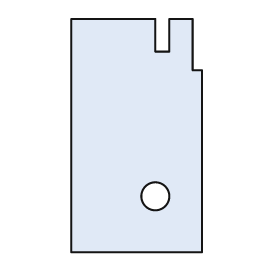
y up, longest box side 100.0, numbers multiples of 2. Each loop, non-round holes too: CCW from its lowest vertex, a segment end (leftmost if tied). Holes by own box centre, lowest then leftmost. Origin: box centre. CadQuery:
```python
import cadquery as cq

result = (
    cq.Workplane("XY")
    .moveTo(-28.0, -50.0)
    .lineTo(28.0, -50.0)
    .lineTo(28.0, 28.0)
    .lineTo(24.0, 28.0)
    .lineTo(24.0, 50.0)
    .lineTo(14.0, 50.0)
    .lineTo(14.0, 36.0)
    .lineTo(8.0, 36.0)
    .lineTo(8.0, 50.0)
    .lineTo(-28.0, 50.0)
    .close()
    .moveTo(8.0, -26.0)
    .circle(6.0)
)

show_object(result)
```